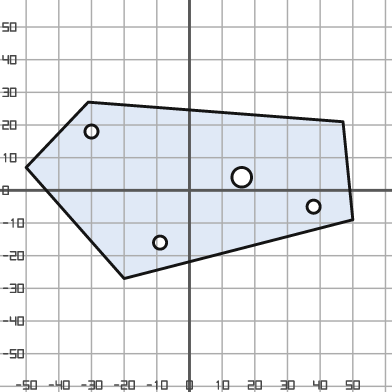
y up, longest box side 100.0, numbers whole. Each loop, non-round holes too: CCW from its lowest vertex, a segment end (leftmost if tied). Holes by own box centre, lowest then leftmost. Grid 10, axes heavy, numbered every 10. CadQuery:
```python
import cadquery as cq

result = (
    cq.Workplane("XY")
    .moveTo(-20.0, -27.0)
    .lineTo(50.0, -9.0)
    .lineTo(47.0, 21.0)
    .lineTo(-31.0, 27.0)
    .lineTo(-50.0, 7.0)
    .close()
    .moveTo(-9.0, -16.0)
    .circle(2.0)
    .moveTo(38.0, -5.0)
    .circle(2.0)
    .moveTo(16.0, 4.0)
    .circle(3.0)
    .moveTo(-30.0, 18.0)
    .circle(2.0)
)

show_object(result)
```